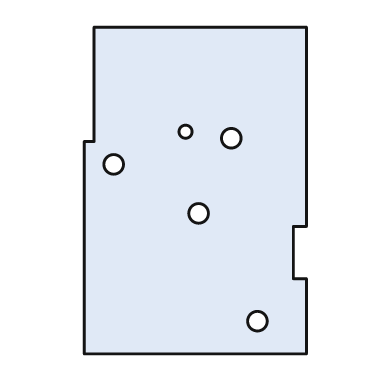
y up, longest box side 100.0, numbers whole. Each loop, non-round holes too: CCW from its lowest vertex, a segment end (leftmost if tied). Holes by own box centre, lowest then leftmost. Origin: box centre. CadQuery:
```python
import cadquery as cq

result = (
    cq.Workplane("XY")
    .moveTo(-34.0, -50.0)
    .lineTo(34.0, -50.0)
    .lineTo(34.0, -27.0)
    .lineTo(30.0, -27.0)
    .lineTo(30.0, -11.0)
    .lineTo(34.0, -11.0)
    .lineTo(34.0, 50.0)
    .lineTo(-31.0, 50.0)
    .lineTo(-31.0, 15.0)
    .lineTo(-34.0, 15.0)
    .close()
    .moveTo(19.0, -40.0)
    .circle(3.0)
    .moveTo(1.0, -7.0)
    .circle(3.0)
    .moveTo(-25.0, 8.0)
    .circle(3.0)
    .moveTo(11.0, 16.0)
    .circle(3.0)
    .moveTo(-3.0, 18.0)
    .circle(2.0)
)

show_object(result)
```